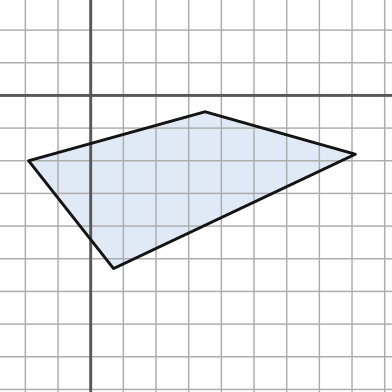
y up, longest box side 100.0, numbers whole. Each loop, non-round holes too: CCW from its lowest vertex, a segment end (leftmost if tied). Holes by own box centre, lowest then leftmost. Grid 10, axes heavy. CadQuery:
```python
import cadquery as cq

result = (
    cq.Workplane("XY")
    .moveTo(7.0, -53.0)
    .lineTo(81.0, -18.0)
    .lineTo(35.0, -5.0)
    .lineTo(-19.0, -20.0)
    .close()
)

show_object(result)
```